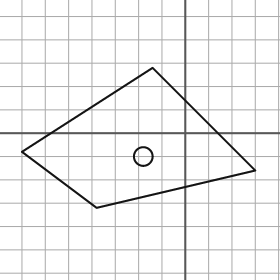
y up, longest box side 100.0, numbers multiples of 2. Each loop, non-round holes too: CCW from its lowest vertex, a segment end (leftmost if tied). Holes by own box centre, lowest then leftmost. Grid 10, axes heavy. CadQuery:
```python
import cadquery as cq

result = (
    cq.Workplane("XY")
    .moveTo(-38.0, -32.0)
    .lineTo(30.0, -16.0)
    .lineTo(-14.0, 28.0)
    .lineTo(-70.0, -8.0)
    .close()
    .moveTo(-18.0, -10.0)
    .circle(4.0)
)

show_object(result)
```